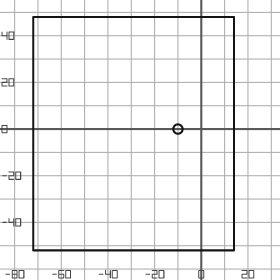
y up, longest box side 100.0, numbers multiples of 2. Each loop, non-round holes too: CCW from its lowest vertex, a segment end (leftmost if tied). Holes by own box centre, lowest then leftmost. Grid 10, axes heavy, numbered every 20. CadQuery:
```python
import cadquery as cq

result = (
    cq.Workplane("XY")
    .moveTo(-72.0, -52.0)
    .lineTo(14.0, -52.0)
    .lineTo(14.0, 48.0)
    .lineTo(-72.0, 48.0)
    .close()
    .moveTo(-10.0, 0.0)
    .circle(2.0)
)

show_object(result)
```